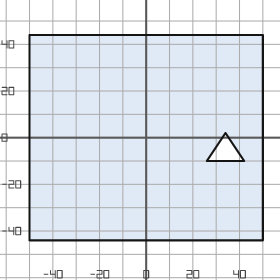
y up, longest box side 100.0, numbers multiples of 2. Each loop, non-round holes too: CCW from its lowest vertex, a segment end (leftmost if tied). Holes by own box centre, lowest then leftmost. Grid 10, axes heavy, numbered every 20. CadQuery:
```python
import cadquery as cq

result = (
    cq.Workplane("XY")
    .moveTo(-50.0, -44.0)
    .lineTo(50.0, -44.0)
    .lineTo(50.0, 44.0)
    .lineTo(-50.0, 44.0)
    .close()
    .moveTo(26.0, -10.0)
    .lineTo(42.0, -10.0)
    .lineTo(34.0, 2.0)
    .close()
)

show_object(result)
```